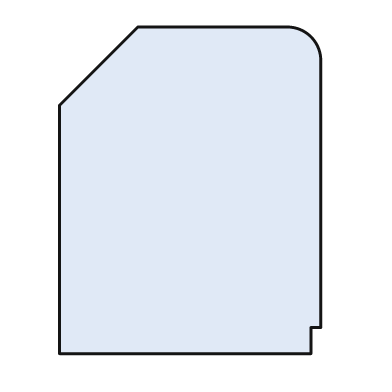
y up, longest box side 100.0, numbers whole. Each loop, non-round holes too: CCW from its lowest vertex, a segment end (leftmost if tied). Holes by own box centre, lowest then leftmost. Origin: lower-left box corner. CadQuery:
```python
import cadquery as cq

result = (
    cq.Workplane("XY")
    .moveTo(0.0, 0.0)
    .lineTo(77.0, 0.0)
    .lineTo(77.0, 8.0)
    .lineTo(80.0, 8.0)
    .lineTo(80.0, 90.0)
    .threePointArc((77.0, 97.0), (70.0, 100.0))
    .lineTo(24.0, 100.0)
    .lineTo(0.0, 76.0)
    .close()
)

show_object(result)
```